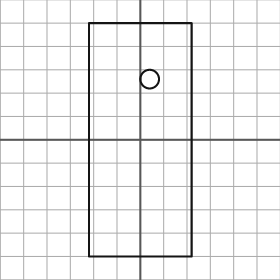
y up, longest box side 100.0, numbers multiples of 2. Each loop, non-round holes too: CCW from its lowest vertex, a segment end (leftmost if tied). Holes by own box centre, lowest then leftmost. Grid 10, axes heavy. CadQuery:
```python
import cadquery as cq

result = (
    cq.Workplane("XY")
    .moveTo(-22.0, -50.0)
    .lineTo(22.0, -50.0)
    .lineTo(22.0, 50.0)
    .lineTo(-22.0, 50.0)
    .close()
    .moveTo(4.0, 26.0)
    .circle(4.0)
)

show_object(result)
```